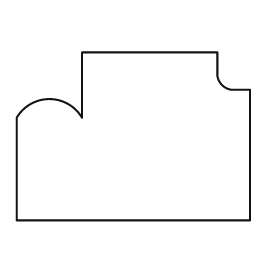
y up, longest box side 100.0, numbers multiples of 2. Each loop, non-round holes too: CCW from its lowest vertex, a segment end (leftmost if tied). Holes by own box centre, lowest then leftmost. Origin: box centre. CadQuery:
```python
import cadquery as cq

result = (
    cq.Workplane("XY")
    .moveTo(-50.0, -36.0)
    .lineTo(50.0, -36.0)
    .lineTo(50.0, 20.0)
    .lineTo(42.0, 20.0)
    .threePointArc((38.0, 22.0), (36.0, 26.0))
    .lineTo(36.0, 36.0)
    .lineTo(-22.0, 36.0)
    .lineTo(-22.0, 8.0)
    .threePointArc((-36.0, 16.0), (-50.0, 8.0))
    .close()
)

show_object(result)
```